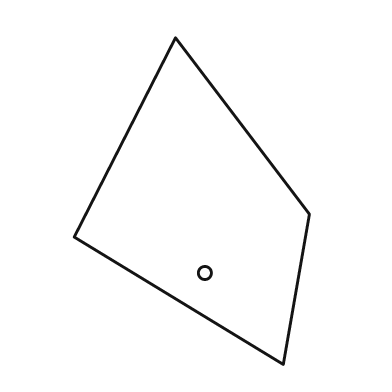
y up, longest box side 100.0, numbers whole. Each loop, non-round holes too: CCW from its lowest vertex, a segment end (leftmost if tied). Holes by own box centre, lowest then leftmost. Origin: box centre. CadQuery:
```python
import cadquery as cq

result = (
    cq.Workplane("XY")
    .moveTo(28.0, -50.0)
    .lineTo(36.0, -4.0)
    .lineTo(-5.0, 50.0)
    .lineTo(-36.0, -11.0)
    .close()
    .moveTo(4.0, -22.0)
    .circle(2.0)
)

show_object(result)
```